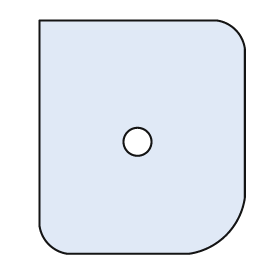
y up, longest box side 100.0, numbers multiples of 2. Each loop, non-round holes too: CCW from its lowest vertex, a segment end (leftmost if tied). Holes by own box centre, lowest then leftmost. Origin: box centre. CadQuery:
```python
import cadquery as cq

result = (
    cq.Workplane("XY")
    .moveTo(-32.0, -50.0)
    .lineTo(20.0, -50.0)
    .threePointArc((36.0, -42.0), (44.0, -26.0))
    .lineTo(44.0, 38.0)
    .threePointArc((40.0, 46.0), (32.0, 50.0))
    .lineTo(-44.0, 50.0)
    .lineTo(-44.0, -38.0)
    .threePointArc((-40.0, -46.0), (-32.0, -50.0))
    .close()
    .moveTo(-2.0, -2.0)
    .circle(6.0)
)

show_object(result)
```